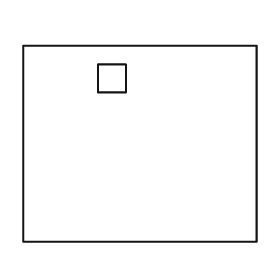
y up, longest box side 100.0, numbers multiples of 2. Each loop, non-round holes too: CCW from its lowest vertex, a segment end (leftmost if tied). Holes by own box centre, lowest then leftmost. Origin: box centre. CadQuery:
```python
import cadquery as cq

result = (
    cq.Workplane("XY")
    .moveTo(-50.0, -42.0)
    .lineTo(50.0, -42.0)
    .lineTo(50.0, 42.0)
    .lineTo(-50.0, 42.0)
    .close()
    .moveTo(-18.0, 22.0)
    .lineTo(-6.0, 22.0)
    .lineTo(-6.0, 34.0)
    .lineTo(-18.0, 34.0)
    .close()
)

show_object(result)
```